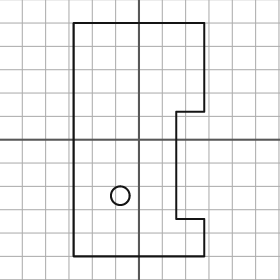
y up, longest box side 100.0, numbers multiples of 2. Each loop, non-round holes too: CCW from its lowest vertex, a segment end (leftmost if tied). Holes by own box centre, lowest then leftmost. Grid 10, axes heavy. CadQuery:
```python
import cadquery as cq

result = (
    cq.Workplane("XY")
    .moveTo(-28.0, -50.0)
    .lineTo(28.0, -50.0)
    .lineTo(28.0, -34.0)
    .lineTo(16.0, -34.0)
    .lineTo(16.0, 12.0)
    .lineTo(28.0, 12.0)
    .lineTo(28.0, 50.0)
    .lineTo(-28.0, 50.0)
    .close()
    .moveTo(-8.0, -24.0)
    .circle(4.0)
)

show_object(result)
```